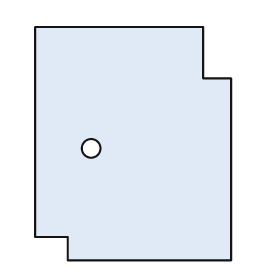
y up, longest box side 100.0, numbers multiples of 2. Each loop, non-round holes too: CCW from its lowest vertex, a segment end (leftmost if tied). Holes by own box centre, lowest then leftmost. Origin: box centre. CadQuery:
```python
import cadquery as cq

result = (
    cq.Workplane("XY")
    .moveTo(-28.0, -50.0)
    .lineTo(42.0, -50.0)
    .lineTo(42.0, 28.0)
    .lineTo(30.0, 28.0)
    .lineTo(30.0, 50.0)
    .lineTo(-42.0, 50.0)
    .lineTo(-42.0, -40.0)
    .lineTo(-28.0, -40.0)
    .close()
    .moveTo(-18.0, -2.0)
    .circle(4.0)
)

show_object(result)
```